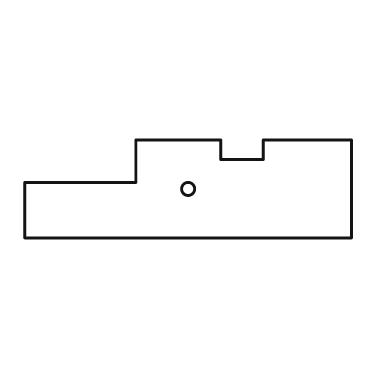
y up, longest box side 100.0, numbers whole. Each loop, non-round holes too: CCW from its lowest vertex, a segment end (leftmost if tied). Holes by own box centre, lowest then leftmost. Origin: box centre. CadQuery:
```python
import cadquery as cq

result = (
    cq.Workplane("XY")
    .moveTo(-50.0, -15.0)
    .lineTo(50.0, -15.0)
    .lineTo(50.0, 15.0)
    .lineTo(23.0, 15.0)
    .lineTo(23.0, 9.0)
    .lineTo(10.0, 9.0)
    .lineTo(10.0, 15.0)
    .lineTo(-16.0, 15.0)
    .lineTo(-16.0, 2.0)
    .lineTo(-50.0, 2.0)
    .close()
    .moveTo(0.0, 0.0)
    .circle(2.0)
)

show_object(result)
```